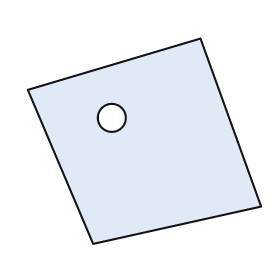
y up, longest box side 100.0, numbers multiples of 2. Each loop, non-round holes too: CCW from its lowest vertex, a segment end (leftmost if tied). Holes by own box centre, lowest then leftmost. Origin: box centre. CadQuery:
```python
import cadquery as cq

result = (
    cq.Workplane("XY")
    .moveTo(-22.0, -44.0)
    .lineTo(50.0, -28.0)
    .lineTo(24.0, 44.0)
    .lineTo(-50.0, 22.0)
    .close()
    .moveTo(-14.0, 10.0)
    .circle(6.0)
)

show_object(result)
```